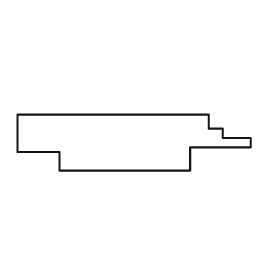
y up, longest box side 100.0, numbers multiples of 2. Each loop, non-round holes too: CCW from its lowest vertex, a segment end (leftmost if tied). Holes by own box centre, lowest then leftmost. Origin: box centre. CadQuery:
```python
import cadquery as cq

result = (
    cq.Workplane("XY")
    .moveTo(-32.0, -12.0)
    .lineTo(24.0, -12.0)
    .lineTo(24.0, -2.0)
    .lineTo(50.0, -2.0)
    .lineTo(50.0, 2.0)
    .lineTo(38.0, 2.0)
    .lineTo(38.0, 6.0)
    .lineTo(32.0, 6.0)
    .lineTo(32.0, 12.0)
    .lineTo(-50.0, 12.0)
    .lineTo(-50.0, -4.0)
    .lineTo(-32.0, -4.0)
    .close()
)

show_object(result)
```